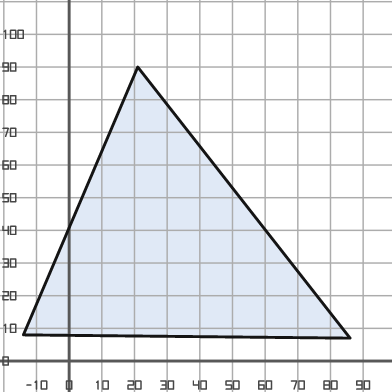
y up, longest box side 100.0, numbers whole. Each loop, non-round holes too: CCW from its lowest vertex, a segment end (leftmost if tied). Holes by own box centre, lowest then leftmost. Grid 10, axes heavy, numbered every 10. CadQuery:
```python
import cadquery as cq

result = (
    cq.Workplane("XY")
    .moveTo(86.0, 7.0)
    .lineTo(21.0, 90.0)
    .lineTo(-14.0, 8.0)
    .close()
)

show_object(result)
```